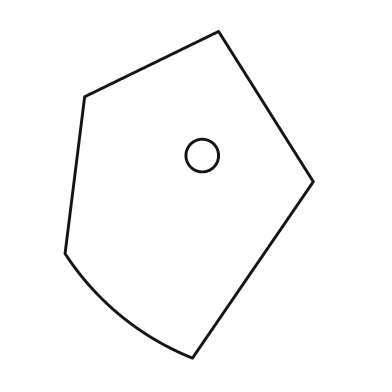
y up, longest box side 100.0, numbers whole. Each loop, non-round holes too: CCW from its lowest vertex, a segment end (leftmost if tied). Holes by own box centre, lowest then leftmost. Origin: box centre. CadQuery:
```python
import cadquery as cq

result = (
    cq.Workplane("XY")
    .moveTo(1.0, -50.0)
    .lineTo(38.0, 4.0)
    .lineTo(9.0, 50.0)
    .lineTo(-32.0, 30.0)
    .lineTo(-38.0, -18.0)
    .threePointArc((-21.0, -37.0), (1.0, -50.0))
    .close()
    .moveTo(4.0, 12.0)
    .circle(5.0)
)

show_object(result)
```